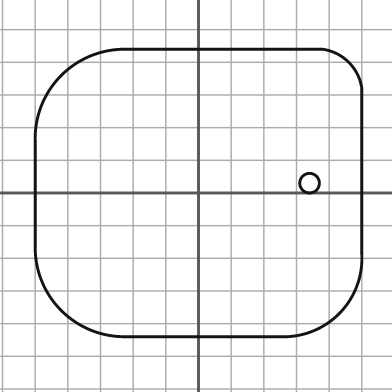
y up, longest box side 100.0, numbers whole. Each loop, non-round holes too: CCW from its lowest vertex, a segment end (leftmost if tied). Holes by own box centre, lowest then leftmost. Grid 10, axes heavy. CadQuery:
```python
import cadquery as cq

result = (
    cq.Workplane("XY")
    .moveTo(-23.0, -44.0)
    .lineTo(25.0, -44.0)
    .threePointArc((43.0, -37.0), (50.0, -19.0))
    .lineTo(50.0, 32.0)
    .threePointArc((46.0, 40.0), (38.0, 44.0))
    .lineTo(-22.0, 44.0)
    .threePointArc((-42.0, 36.0), (-50.0, 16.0))
    .lineTo(-50.0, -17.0)
    .threePointArc((-42.0, -36.0), (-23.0, -44.0))
    .close()
    .moveTo(34.0, 3.0)
    .circle(3.0)
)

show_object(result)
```